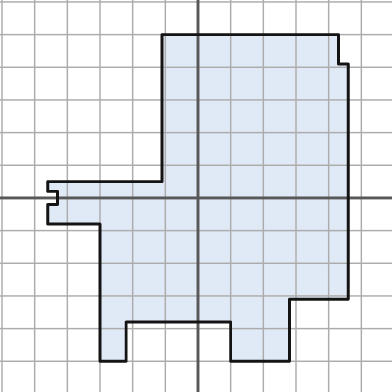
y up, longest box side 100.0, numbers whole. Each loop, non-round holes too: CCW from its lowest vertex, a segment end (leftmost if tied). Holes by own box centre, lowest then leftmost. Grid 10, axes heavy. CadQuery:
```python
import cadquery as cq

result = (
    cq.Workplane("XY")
    .moveTo(-30.0, -50.0)
    .lineTo(-22.0, -50.0)
    .lineTo(-22.0, -38.0)
    .lineTo(10.0, -38.0)
    .lineTo(10.0, -50.0)
    .lineTo(28.0, -50.0)
    .lineTo(28.0, -31.0)
    .lineTo(46.0, -31.0)
    .lineTo(46.0, 41.0)
    .lineTo(43.0, 41.0)
    .lineTo(43.0, 50.0)
    .lineTo(-11.0, 50.0)
    .lineTo(-11.0, 5.0)
    .lineTo(-46.0, 5.0)
    .lineTo(-46.0, 2.0)
    .lineTo(-43.0, 2.0)
    .lineTo(-43.0, -2.0)
    .lineTo(-46.0, -2.0)
    .lineTo(-46.0, -8.0)
    .lineTo(-30.0, -8.0)
    .close()
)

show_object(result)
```